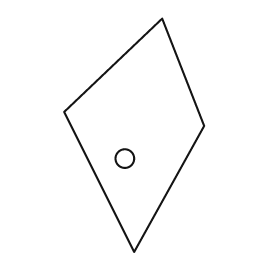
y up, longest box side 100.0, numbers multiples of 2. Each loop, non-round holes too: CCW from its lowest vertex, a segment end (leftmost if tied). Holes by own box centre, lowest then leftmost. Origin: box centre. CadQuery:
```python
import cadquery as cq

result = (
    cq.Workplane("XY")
    .moveTo(0.0, -50.0)
    .lineTo(30.0, 4.0)
    .lineTo(12.0, 50.0)
    .lineTo(-30.0, 10.0)
    .close()
    .moveTo(-4.0, -10.0)
    .circle(4.0)
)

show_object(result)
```